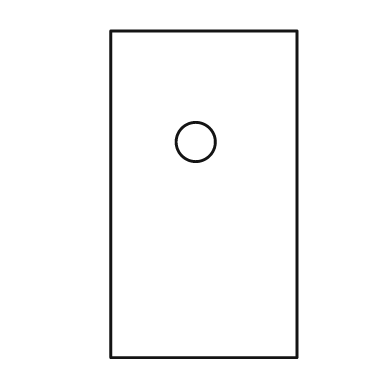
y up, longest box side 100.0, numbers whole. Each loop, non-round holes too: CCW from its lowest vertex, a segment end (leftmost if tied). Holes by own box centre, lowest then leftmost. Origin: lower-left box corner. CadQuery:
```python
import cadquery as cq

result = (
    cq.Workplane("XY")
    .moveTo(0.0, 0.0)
    .lineTo(57.0, 0.0)
    .lineTo(57.0, 100.0)
    .lineTo(0.0, 100.0)
    .close()
    .moveTo(26.0, 66.0)
    .circle(6.0)
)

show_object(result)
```